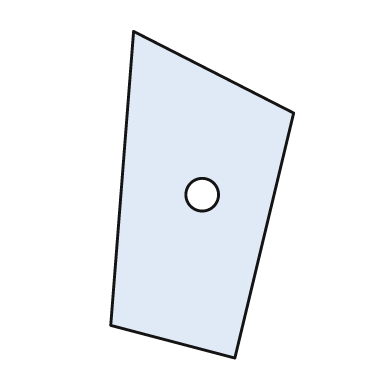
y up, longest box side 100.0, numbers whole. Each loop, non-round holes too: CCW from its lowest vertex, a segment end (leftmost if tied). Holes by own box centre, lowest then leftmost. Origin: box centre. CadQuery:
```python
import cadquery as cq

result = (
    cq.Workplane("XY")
    .moveTo(10.0, -50.0)
    .lineTo(28.0, 25.0)
    .lineTo(-21.0, 50.0)
    .lineTo(-28.0, -40.0)
    .close()
    .moveTo(0.0, 0.0)
    .circle(5.0)
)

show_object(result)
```